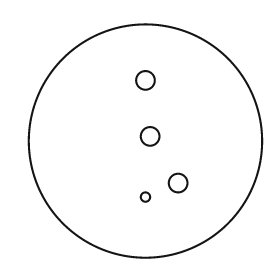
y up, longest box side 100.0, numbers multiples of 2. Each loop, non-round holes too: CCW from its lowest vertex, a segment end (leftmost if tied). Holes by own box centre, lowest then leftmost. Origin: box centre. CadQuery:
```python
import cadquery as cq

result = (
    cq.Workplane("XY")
    .moveTo(0.0, 0.0)
    .circle(50.0)
    .moveTo(0.0, -24.0)
    .circle(2.0)
    .moveTo(14.0, -18.0)
    .circle(4.0)
    .moveTo(2.0, 2.0)
    .circle(4.0)
    .moveTo(0.0, 26.0)
    .circle(4.0)
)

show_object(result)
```